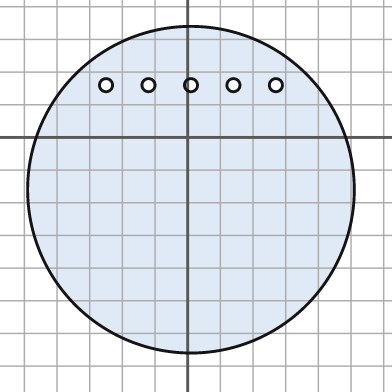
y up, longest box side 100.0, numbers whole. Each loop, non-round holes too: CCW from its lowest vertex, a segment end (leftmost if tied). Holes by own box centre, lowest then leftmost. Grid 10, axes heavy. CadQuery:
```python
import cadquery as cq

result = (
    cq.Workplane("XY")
    .moveTo(1.0, -16.0)
    .circle(50.0)
    .moveTo(-25.0, 16.0)
    .circle(2.0)
    .moveTo(-12.0, 16.0)
    .circle(2.0)
    .moveTo(1.0, 16.0)
    .circle(2.0)
    .moveTo(14.0, 16.0)
    .circle(2.0)
    .moveTo(27.0, 16.0)
    .circle(2.0)
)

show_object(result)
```